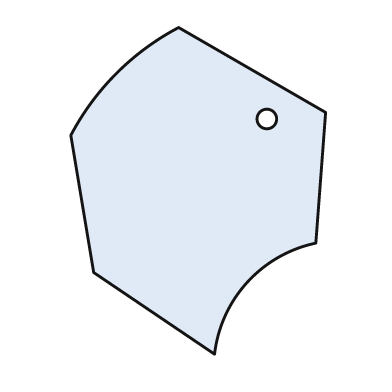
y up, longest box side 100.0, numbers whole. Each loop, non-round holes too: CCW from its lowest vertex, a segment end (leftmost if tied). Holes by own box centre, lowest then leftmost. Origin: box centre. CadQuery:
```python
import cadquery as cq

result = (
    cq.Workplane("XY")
    .moveTo(5.0, -50.0)
    .threePointArc((15.0, -28.0), (36.0, -16.0))
    .lineTo(39.0, 24.0)
    .lineTo(-6.0, 50.0)
    .threePointArc((-25.0, 36.0), (-39.0, 17.0))
    .lineTo(-32.0, -25.0)
    .close()
    .moveTo(21.0, 22.0)
    .circle(3.0)
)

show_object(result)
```